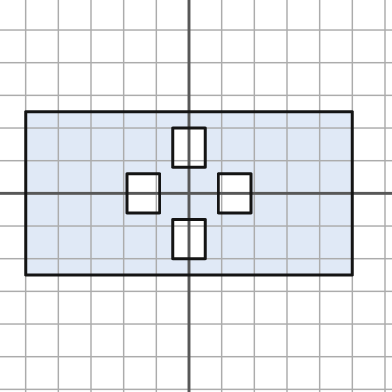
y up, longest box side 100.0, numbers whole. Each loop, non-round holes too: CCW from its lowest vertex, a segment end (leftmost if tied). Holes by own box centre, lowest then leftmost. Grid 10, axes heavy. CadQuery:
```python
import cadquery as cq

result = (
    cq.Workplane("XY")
    .moveTo(-50.0, -25.0)
    .lineTo(50.0, -25.0)
    .lineTo(50.0, 25.0)
    .lineTo(-50.0, 25.0)
    .close()
    .moveTo(-5.0, -20.0)
    .lineTo(5.0, -20.0)
    .lineTo(5.0, -8.0)
    .lineTo(-5.0, -8.0)
    .close()
    .moveTo(-19.0, -6.0)
    .lineTo(-9.0, -6.0)
    .lineTo(-9.0, 6.0)
    .lineTo(-19.0, 6.0)
    .close()
    .moveTo(9.0, -6.0)
    .lineTo(19.0, -6.0)
    .lineTo(19.0, 6.0)
    .lineTo(9.0, 6.0)
    .close()
    .moveTo(-5.0, 8.0)
    .lineTo(5.0, 8.0)
    .lineTo(5.0, 20.0)
    .lineTo(-5.0, 20.0)
    .close()
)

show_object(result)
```